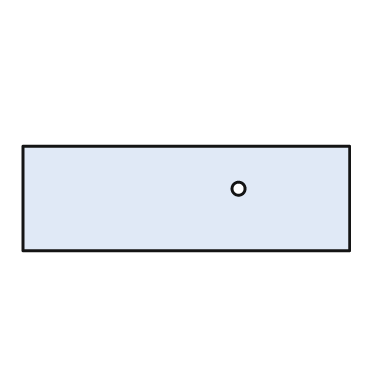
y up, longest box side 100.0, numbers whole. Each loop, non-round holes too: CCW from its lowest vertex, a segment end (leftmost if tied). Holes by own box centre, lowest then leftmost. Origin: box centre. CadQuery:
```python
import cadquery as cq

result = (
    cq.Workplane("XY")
    .moveTo(-50.0, -16.0)
    .lineTo(50.0, -16.0)
    .lineTo(50.0, 16.0)
    .lineTo(-50.0, 16.0)
    .close()
    .moveTo(16.0, 3.0)
    .circle(2.0)
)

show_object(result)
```